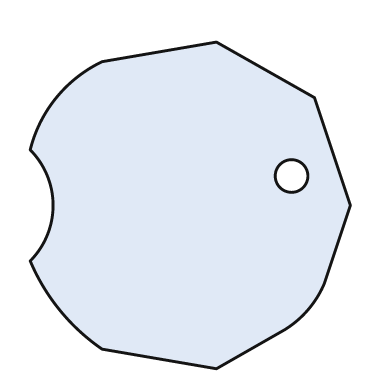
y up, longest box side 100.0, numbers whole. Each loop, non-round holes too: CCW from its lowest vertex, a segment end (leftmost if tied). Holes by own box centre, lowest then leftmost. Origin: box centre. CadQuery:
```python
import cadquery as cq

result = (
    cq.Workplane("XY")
    .moveTo(8.0, -50.0)
    .lineTo(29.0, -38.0)
    .threePointArc((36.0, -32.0), (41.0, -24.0))
    .lineTo(49.0, 0.0)
    .lineTo(38.0, 33.0)
    .lineTo(8.0, 50.0)
    .lineTo(-27.0, 44.0)
    .threePointArc((-41.0, 33.0), (-49.0, 17.0))
    .threePointArc((-42.0, 0.0), (-49.0, -17.0))
    .threePointArc((-40.0, -32.0), (-27.0, -44.0))
    .close()
    .moveTo(31.0, 9.0)
    .circle(5.0)
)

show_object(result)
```